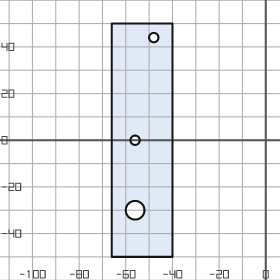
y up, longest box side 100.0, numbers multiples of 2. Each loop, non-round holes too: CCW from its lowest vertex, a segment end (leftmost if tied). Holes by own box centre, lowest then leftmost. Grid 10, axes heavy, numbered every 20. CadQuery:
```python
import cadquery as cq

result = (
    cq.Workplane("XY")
    .moveTo(-66.0, -50.0)
    .lineTo(-40.0, -50.0)
    .lineTo(-40.0, 50.0)
    .lineTo(-66.0, 50.0)
    .close()
    .moveTo(-56.0, -30.0)
    .circle(4.0)
    .moveTo(-56.0, 0.0)
    .circle(2.0)
    .moveTo(-48.0, 44.0)
    .circle(2.0)
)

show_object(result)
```